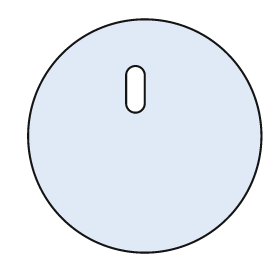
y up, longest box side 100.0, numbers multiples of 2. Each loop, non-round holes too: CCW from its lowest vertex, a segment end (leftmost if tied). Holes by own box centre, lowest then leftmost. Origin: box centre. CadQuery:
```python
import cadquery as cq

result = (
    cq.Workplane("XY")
    .moveTo(0.0, 0.0)
    .circle(50.0)
    .moveTo(-8.0, 14.0)
    .threePointArc((-4.0, 10.0), (0.0, 14.0))
    .lineTo(0.0, 26.0)
    .threePointArc((-4.0, 30.0), (-8.0, 26.0))
    .close()
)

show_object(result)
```